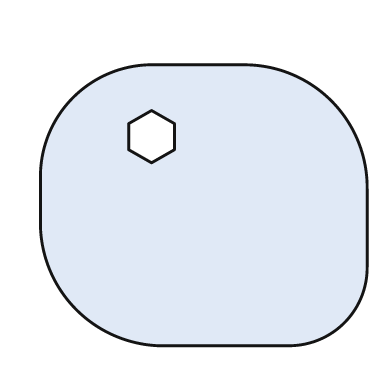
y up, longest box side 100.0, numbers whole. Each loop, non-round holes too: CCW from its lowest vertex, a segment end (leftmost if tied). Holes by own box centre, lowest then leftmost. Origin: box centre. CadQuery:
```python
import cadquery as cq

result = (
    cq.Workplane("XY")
    .moveTo(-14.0, -43.0)
    .lineTo(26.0, -43.0)
    .threePointArc((43.0, -36.0), (50.0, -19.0))
    .lineTo(50.0, 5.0)
    .threePointArc((39.0, 32.0), (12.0, 43.0))
    .lineTo(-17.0, 43.0)
    .threePointArc((-40.0, 33.0), (-50.0, 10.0))
    .lineTo(-50.0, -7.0)
    .threePointArc((-39.0, -32.0), (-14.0, -43.0))
    .close()
    .moveTo(-16.0, 13.0)
    .lineTo(-9.0, 17.0)
    .lineTo(-9.0, 25.0)
    .lineTo(-16.0, 29.0)
    .lineTo(-23.0, 25.0)
    .lineTo(-23.0, 17.0)
    .close()
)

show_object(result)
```